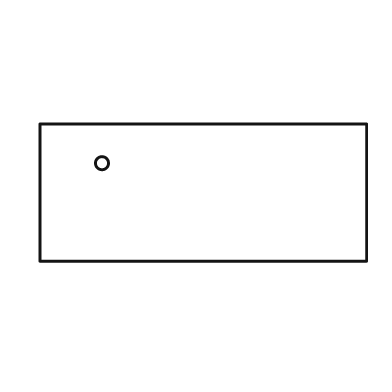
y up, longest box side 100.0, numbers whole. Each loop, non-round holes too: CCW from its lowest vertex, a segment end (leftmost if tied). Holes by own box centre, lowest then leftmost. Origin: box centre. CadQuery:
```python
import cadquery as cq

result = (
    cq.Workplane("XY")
    .moveTo(-50.0, -21.0)
    .lineTo(50.0, -21.0)
    .lineTo(50.0, 21.0)
    .lineTo(-50.0, 21.0)
    .close()
    .moveTo(-31.0, 9.0)
    .circle(2.0)
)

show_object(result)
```